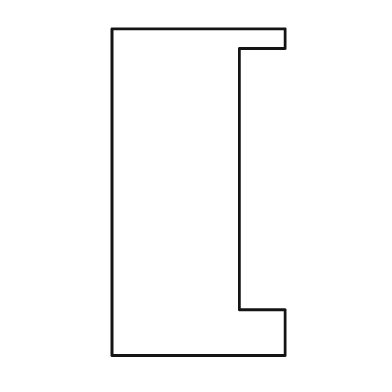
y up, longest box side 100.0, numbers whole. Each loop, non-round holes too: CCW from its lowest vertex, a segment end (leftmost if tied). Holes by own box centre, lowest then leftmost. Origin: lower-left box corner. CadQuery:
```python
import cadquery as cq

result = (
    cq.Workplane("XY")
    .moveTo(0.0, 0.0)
    .lineTo(53.0, 0.0)
    .lineTo(53.0, 14.0)
    .lineTo(39.0, 14.0)
    .lineTo(39.0, 94.0)
    .lineTo(53.0, 94.0)
    .lineTo(53.0, 100.0)
    .lineTo(0.0, 100.0)
    .close()
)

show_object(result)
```